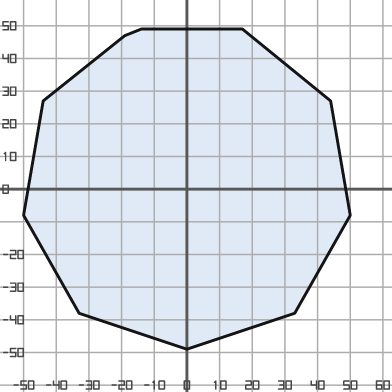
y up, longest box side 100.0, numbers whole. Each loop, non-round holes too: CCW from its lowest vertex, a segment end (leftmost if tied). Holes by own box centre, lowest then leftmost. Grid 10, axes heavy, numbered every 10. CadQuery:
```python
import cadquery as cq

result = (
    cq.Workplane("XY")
    .moveTo(0.0, -49.0)
    .lineTo(33.0, -38.0)
    .lineTo(50.0, -8.0)
    .lineTo(44.0, 27.0)
    .lineTo(17.0, 49.0)
    .lineTo(-14.0, 49.0)
    .lineTo(-19.0, 47.0)
    .lineTo(-44.0, 27.0)
    .lineTo(-50.0, -8.0)
    .lineTo(-33.0, -38.0)
    .close()
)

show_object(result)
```